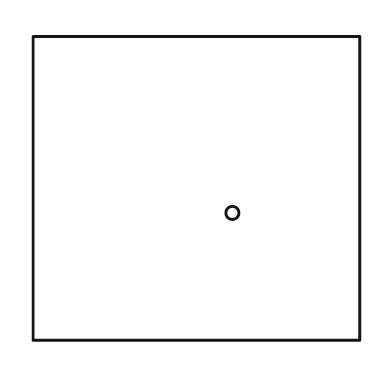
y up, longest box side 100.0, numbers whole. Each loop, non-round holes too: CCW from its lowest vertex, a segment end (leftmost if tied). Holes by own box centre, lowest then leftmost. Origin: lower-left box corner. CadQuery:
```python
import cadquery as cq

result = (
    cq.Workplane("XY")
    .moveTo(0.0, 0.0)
    .lineTo(100.0, 0.0)
    .lineTo(100.0, 93.0)
    .lineTo(0.0, 93.0)
    .close()
    .moveTo(61.0, 39.0)
    .circle(2.0)
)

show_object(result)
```